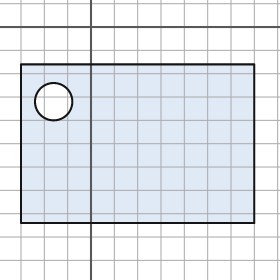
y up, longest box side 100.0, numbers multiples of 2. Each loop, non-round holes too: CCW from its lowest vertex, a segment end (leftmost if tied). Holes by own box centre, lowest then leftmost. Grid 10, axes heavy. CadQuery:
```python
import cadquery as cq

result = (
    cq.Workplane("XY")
    .moveTo(-30.0, -84.0)
    .lineTo(70.0, -84.0)
    .lineTo(70.0, -16.0)
    .lineTo(-30.0, -16.0)
    .close()
    .moveTo(-16.0, -32.0)
    .circle(8.0)
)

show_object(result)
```